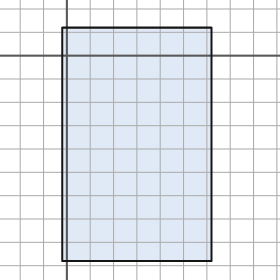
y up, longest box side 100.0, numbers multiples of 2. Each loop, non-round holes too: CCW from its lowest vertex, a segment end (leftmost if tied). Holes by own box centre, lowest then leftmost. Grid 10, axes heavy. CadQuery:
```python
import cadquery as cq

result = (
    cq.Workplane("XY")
    .moveTo(-2.0, -88.0)
    .lineTo(62.0, -88.0)
    .lineTo(62.0, 12.0)
    .lineTo(-2.0, 12.0)
    .close()
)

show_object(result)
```